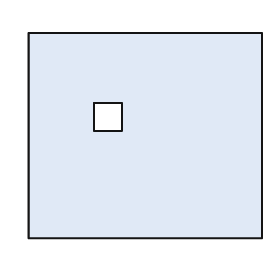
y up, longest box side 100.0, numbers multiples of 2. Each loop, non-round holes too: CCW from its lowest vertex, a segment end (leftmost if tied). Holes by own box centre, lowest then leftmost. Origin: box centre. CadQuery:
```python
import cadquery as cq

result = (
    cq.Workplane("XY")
    .moveTo(-50.0, -44.0)
    .lineTo(50.0, -44.0)
    .lineTo(50.0, 44.0)
    .lineTo(-50.0, 44.0)
    .close()
    .moveTo(-22.0, 2.0)
    .lineTo(-10.0, 2.0)
    .lineTo(-10.0, 14.0)
    .lineTo(-22.0, 14.0)
    .close()
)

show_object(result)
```